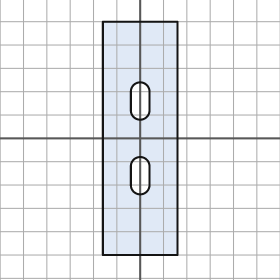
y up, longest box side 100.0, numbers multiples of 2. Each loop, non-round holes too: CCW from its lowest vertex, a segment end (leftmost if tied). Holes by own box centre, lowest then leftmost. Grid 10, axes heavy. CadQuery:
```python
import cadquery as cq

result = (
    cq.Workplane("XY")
    .moveTo(-16.0, -50.0)
    .lineTo(16.0, -50.0)
    .lineTo(16.0, 50.0)
    .lineTo(-16.0, 50.0)
    .close()
    .moveTo(-4.0, -20.0)
    .threePointArc((0.0, -24.0), (4.0, -20.0))
    .lineTo(4.0, -12.0)
    .threePointArc((0.0, -8.0), (-4.0, -12.0))
    .close()
    .moveTo(-4.0, 12.0)
    .threePointArc((0.0, 8.0), (4.0, 12.0))
    .lineTo(4.0, 20.0)
    .threePointArc((0.0, 24.0), (-4.0, 20.0))
    .close()
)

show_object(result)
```